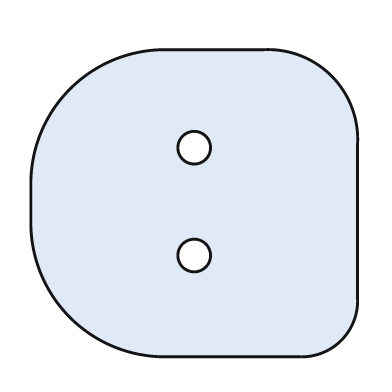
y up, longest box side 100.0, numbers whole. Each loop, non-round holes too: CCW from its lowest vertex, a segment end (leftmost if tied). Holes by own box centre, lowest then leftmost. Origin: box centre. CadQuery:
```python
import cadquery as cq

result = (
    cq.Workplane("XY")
    .moveTo(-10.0, -47.0)
    .lineTo(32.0, -47.0)
    .threePointArc((45.0, -42.0), (50.0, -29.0))
    .lineTo(50.0, 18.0)
    .threePointArc((42.0, 39.0), (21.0, 47.0))
    .lineTo(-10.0, 47.0)
    .threePointArc((-38.0, 35.0), (-50.0, 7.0))
    .lineTo(-50.0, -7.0)
    .threePointArc((-38.0, -35.0), (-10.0, -47.0))
    .close()
    .moveTo(0.0, -16.0)
    .circle(5.0)
    .moveTo(0.0, 17.0)
    .circle(5.0)
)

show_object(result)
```